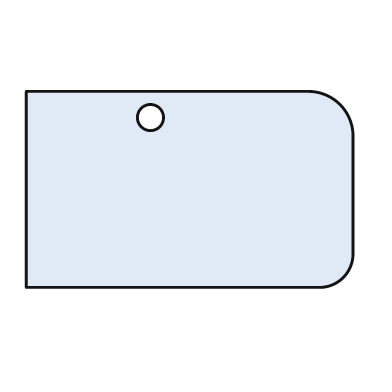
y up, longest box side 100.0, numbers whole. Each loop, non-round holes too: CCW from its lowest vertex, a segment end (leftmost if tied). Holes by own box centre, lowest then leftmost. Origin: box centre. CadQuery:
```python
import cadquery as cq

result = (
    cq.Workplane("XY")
    .moveTo(-50.0, -30.0)
    .lineTo(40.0, -30.0)
    .threePointArc((47.0, -27.0), (50.0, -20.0))
    .lineTo(50.0, 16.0)
    .threePointArc((46.0, 26.0), (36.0, 30.0))
    .lineTo(-50.0, 30.0)
    .close()
    .moveTo(-12.0, 22.0)
    .circle(4.0)
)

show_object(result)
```